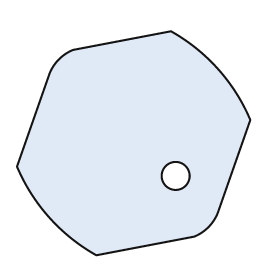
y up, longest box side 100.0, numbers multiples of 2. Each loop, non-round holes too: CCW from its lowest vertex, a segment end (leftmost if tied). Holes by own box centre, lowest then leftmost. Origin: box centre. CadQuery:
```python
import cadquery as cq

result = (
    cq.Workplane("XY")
    .moveTo(-16.0, -48.0)
    .lineTo(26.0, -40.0)
    .threePointArc((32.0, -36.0), (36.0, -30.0))
    .lineTo(50.0, 10.0)
    .threePointArc((36.0, 32.0), (16.0, 48.0))
    .lineTo(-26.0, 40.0)
    .threePointArc((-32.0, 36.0), (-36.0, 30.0))
    .lineTo(-50.0, -10.0)
    .threePointArc((-36.0, -32.0), (-16.0, -48.0))
    .close()
    .moveTo(18.0, -14.0)
    .circle(6.0)
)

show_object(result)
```